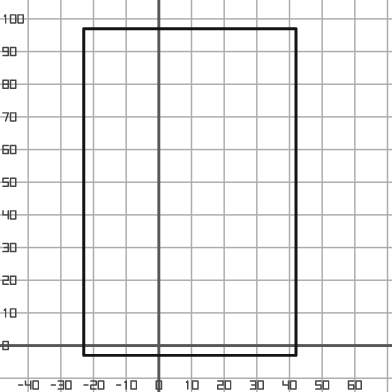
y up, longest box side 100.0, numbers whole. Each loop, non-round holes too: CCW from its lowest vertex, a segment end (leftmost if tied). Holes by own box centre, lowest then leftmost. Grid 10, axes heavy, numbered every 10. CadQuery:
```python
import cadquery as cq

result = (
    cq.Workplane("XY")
    .moveTo(-23.0, -3.0)
    .lineTo(42.0, -3.0)
    .lineTo(42.0, 97.0)
    .lineTo(-23.0, 97.0)
    .close()
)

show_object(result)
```